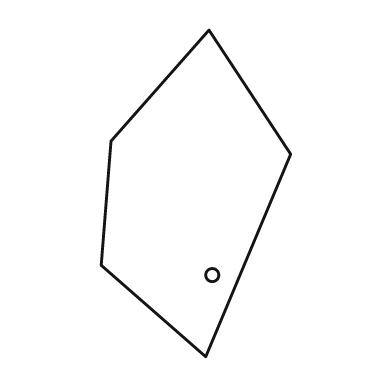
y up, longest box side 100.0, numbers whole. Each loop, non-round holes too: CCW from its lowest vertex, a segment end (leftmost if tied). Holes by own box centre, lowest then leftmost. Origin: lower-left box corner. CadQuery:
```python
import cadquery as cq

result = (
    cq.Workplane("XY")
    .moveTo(32.0, 0.0)
    .lineTo(58.0, 62.0)
    .lineTo(33.0, 100.0)
    .lineTo(3.0, 66.0)
    .lineTo(0.0, 28.0)
    .close()
    .moveTo(34.0, 25.0)
    .circle(2.0)
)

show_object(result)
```